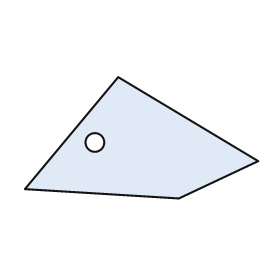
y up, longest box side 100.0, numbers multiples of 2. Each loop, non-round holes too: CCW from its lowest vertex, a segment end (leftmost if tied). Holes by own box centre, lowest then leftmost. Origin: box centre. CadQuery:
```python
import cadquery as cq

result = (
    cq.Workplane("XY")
    .moveTo(16.0, -26.0)
    .lineTo(50.0, -10.0)
    .lineTo(-10.0, 26.0)
    .lineTo(-50.0, -22.0)
    .close()
    .moveTo(-20.0, -2.0)
    .circle(4.0)
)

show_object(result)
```